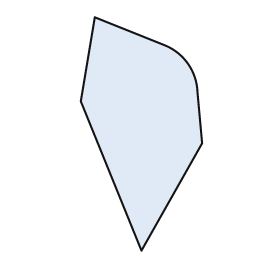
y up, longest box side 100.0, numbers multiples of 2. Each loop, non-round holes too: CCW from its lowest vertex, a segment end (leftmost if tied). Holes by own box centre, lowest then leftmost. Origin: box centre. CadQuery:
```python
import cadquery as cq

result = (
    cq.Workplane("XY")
    .moveTo(0.0, -50.0)
    .lineTo(26.0, -4.0)
    .lineTo(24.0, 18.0)
    .threePointArc((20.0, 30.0), (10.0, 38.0))
    .lineTo(-20.0, 50.0)
    .lineTo(-26.0, 14.0)
    .close()
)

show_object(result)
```